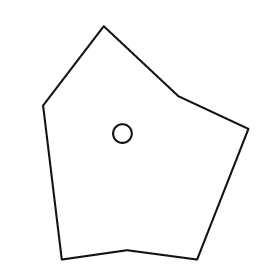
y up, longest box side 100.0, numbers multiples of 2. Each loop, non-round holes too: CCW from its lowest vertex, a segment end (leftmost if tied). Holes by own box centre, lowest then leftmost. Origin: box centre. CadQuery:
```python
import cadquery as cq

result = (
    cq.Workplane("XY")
    .moveTo(-36.0, -50.0)
    .lineTo(-8.0, -46.0)
    .lineTo(22.0, -50.0)
    .lineTo(44.0, 6.0)
    .lineTo(14.0, 20.0)
    .lineTo(-18.0, 50.0)
    .lineTo(-44.0, 16.0)
    .close()
    .moveTo(-10.0, 4.0)
    .circle(4.0)
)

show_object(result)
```